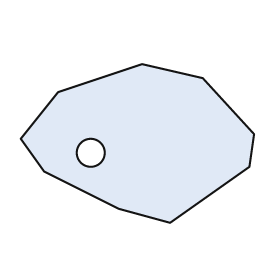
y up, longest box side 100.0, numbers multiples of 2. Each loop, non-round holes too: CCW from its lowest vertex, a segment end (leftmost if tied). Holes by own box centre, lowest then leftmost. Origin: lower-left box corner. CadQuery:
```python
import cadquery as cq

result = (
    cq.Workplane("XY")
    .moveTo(64.0, 0.0)
    .lineTo(98.0, 24.0)
    .lineTo(100.0, 38.0)
    .lineTo(78.0, 62.0)
    .lineTo(52.0, 68.0)
    .lineTo(16.0, 56.0)
    .lineTo(0.0, 36.0)
    .lineTo(10.0, 22.0)
    .lineTo(42.0, 6.0)
    .close()
    .moveTo(30.0, 30.0)
    .circle(6.0)
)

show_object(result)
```